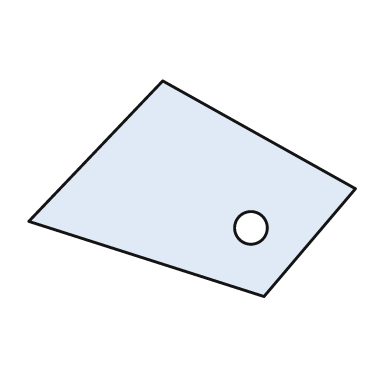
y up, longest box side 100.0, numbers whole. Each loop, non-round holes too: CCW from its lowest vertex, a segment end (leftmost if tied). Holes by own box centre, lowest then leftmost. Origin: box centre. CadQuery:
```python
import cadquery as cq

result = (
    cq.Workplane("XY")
    .moveTo(22.0, -33.0)
    .lineTo(50.0, 0.0)
    .lineTo(-9.0, 33.0)
    .lineTo(-50.0, -10.0)
    .close()
    .moveTo(18.0, -12.0)
    .circle(5.0)
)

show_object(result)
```